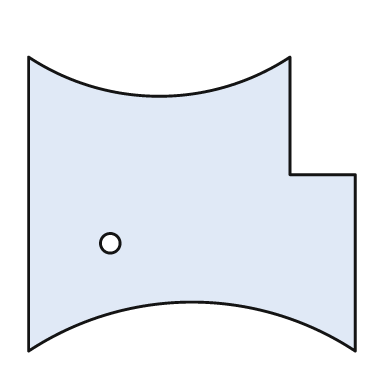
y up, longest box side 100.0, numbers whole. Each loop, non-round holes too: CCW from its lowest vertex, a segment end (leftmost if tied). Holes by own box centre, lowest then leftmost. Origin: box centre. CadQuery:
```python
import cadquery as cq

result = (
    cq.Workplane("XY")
    .moveTo(-50.0, -45.0)
    .threePointArc((0.0, -30.0), (50.0, -45.0))
    .lineTo(50.0, 9.0)
    .lineTo(30.0, 9.0)
    .lineTo(30.0, 45.0)
    .threePointArc((-10.0, 33.0), (-50.0, 45.0))
    .close()
    .moveTo(-25.0, -12.0)
    .circle(3.0)
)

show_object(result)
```